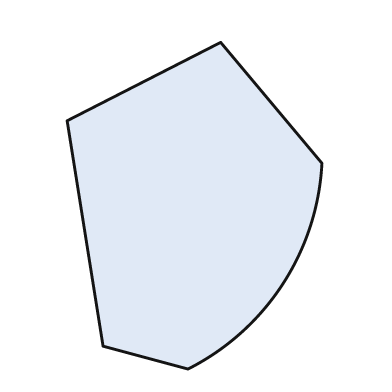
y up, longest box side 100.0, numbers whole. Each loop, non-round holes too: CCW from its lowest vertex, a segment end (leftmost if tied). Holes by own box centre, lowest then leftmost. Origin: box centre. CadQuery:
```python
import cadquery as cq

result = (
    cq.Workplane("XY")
    .moveTo(-2.0, -50.0)
    .threePointArc((27.0, -24.0), (39.0, 13.0))
    .lineTo(8.0, 50.0)
    .lineTo(-39.0, 26.0)
    .lineTo(-28.0, -43.0)
    .close()
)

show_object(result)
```